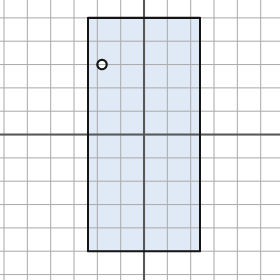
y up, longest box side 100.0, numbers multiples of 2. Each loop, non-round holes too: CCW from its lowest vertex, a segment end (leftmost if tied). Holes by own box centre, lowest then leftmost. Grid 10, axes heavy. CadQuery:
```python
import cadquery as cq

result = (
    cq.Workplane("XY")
    .moveTo(-24.0, -50.0)
    .lineTo(24.0, -50.0)
    .lineTo(24.0, 50.0)
    .lineTo(-24.0, 50.0)
    .close()
    .moveTo(-18.0, 30.0)
    .circle(2.0)
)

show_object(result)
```